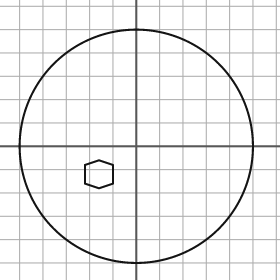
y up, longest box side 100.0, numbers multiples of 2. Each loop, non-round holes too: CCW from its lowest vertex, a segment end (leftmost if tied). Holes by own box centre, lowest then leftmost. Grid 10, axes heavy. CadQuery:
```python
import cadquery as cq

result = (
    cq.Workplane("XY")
    .moveTo(0.0, 0.0)
    .circle(50.0)
    .moveTo(-16.0, -18.0)
    .lineTo(-10.0, -16.0)
    .lineTo(-10.0, -8.0)
    .lineTo(-16.0, -6.0)
    .lineTo(-22.0, -8.0)
    .lineTo(-22.0, -16.0)
    .close()
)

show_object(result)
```